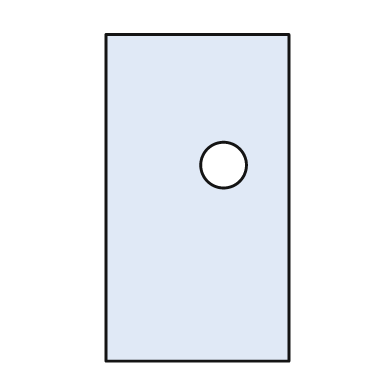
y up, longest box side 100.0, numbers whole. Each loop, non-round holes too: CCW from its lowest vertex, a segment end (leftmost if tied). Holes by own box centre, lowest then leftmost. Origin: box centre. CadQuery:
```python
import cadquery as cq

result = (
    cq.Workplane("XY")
    .moveTo(-28.0, -50.0)
    .lineTo(28.0, -50.0)
    .lineTo(28.0, 50.0)
    .lineTo(-28.0, 50.0)
    .close()
    .moveTo(8.0, 10.0)
    .circle(7.0)
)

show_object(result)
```